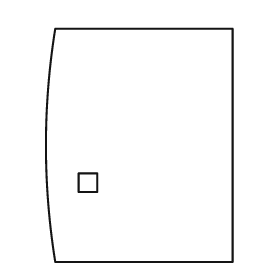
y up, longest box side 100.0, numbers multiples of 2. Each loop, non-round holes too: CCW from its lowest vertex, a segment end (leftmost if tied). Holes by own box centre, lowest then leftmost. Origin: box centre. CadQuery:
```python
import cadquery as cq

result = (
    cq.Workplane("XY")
    .moveTo(-36.0, -50.0)
    .lineTo(40.0, -50.0)
    .lineTo(40.0, 50.0)
    .lineTo(-36.0, 50.0)
    .threePointArc((-40.0, 0.0), (-36.0, -50.0))
    .close()
    .moveTo(-26.0, -20.0)
    .lineTo(-18.0, -20.0)
    .lineTo(-18.0, -12.0)
    .lineTo(-26.0, -12.0)
    .close()
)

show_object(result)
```